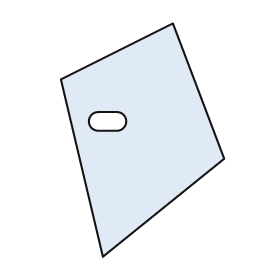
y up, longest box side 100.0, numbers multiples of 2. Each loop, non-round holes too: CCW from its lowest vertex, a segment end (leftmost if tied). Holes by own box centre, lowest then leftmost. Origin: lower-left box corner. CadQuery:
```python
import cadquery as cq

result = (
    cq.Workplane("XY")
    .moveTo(18.0, 0.0)
    .lineTo(70.0, 42.0)
    .lineTo(48.0, 100.0)
    .lineTo(0.0, 76.0)
    .close()
    .moveTo(16.0, 54.0)
    .lineTo(24.0, 54.0)
    .threePointArc((28.0, 58.0), (24.0, 62.0))
    .lineTo(16.0, 62.0)
    .threePointArc((12.0, 58.0), (16.0, 54.0))
    .close()
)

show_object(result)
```